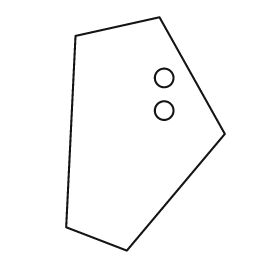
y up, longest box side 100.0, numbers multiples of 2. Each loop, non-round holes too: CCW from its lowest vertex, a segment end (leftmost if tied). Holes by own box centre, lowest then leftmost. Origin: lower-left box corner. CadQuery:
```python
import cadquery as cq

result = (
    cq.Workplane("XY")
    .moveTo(26.0, 0.0)
    .lineTo(68.0, 50.0)
    .lineTo(40.0, 100.0)
    .lineTo(4.0, 92.0)
    .lineTo(0.0, 10.0)
    .close()
    .moveTo(42.0, 60.0)
    .circle(4.0)
    .moveTo(42.0, 74.0)
    .circle(4.0)
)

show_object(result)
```